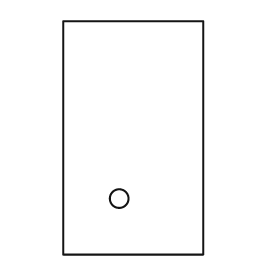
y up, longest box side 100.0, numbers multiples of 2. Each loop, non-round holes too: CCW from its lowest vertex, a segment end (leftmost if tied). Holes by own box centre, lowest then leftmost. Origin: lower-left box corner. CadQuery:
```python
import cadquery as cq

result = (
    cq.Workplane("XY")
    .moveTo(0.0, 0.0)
    .lineTo(60.0, 0.0)
    .lineTo(60.0, 100.0)
    .lineTo(0.0, 100.0)
    .close()
    .moveTo(24.0, 24.0)
    .circle(4.0)
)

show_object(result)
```